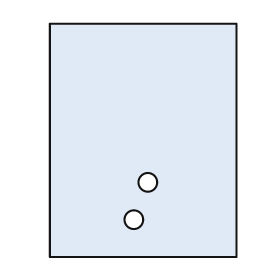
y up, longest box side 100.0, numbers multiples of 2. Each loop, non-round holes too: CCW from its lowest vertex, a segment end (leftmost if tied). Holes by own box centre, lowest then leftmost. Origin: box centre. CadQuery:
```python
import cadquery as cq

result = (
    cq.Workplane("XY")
    .moveTo(-40.0, -50.0)
    .lineTo(40.0, -50.0)
    .lineTo(40.0, 50.0)
    .lineTo(-40.0, 50.0)
    .close()
    .moveTo(-4.0, -34.0)
    .circle(4.0)
    .moveTo(2.0, -18.0)
    .circle(4.0)
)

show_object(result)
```